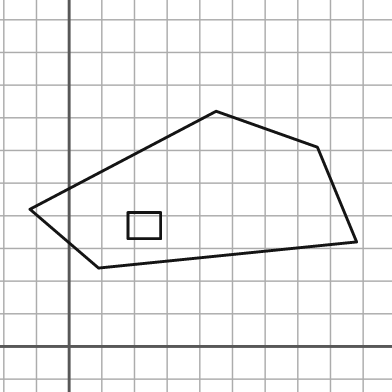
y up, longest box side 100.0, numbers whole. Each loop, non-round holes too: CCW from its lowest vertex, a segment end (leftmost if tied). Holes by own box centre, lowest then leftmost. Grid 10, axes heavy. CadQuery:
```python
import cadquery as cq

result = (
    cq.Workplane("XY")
    .moveTo(9.0, 24.0)
    .lineTo(88.0, 32.0)
    .lineTo(76.0, 61.0)
    .lineTo(45.0, 72.0)
    .lineTo(-12.0, 42.0)
    .close()
    .moveTo(18.0, 33.0)
    .lineTo(28.0, 33.0)
    .lineTo(28.0, 41.0)
    .lineTo(18.0, 41.0)
    .close()
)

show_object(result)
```